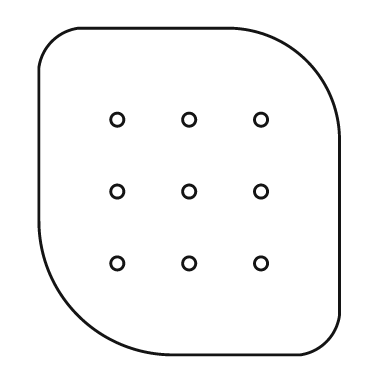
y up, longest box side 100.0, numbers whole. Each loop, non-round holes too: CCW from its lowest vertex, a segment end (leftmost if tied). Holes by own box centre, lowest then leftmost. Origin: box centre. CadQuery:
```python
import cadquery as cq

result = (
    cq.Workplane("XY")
    .moveTo(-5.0, -50.0)
    .lineTo(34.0, -50.0)
    .threePointArc((42.0, -46.0), (46.0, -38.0))
    .lineTo(46.0, 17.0)
    .threePointArc((36.0, 40.0), (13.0, 50.0))
    .lineTo(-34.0, 50.0)
    .threePointArc((-42.0, 46.0), (-46.0, 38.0))
    .lineTo(-46.0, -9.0)
    .threePointArc((-34.0, -38.0), (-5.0, -50.0))
    .close()
    .moveTo(-22.0, -22.0)
    .circle(2.0)
    .moveTo(0.0, -22.0)
    .circle(2.0)
    .moveTo(22.0, -22.0)
    .circle(2.0)
    .moveTo(-22.0, 0.0)
    .circle(2.0)
    .moveTo(0.0, 0.0)
    .circle(2.0)
    .moveTo(22.0, 0.0)
    .circle(2.0)
    .moveTo(-22.0, 22.0)
    .circle(2.0)
    .moveTo(0.0, 22.0)
    .circle(2.0)
    .moveTo(22.0, 22.0)
    .circle(2.0)
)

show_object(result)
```